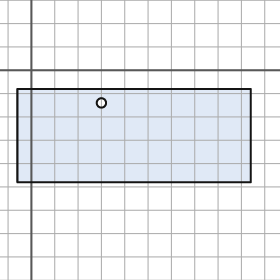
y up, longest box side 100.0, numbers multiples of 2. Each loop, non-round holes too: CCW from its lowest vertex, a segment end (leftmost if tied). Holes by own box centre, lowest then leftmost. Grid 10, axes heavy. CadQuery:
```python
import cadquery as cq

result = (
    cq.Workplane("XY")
    .moveTo(-6.0, -48.0)
    .lineTo(94.0, -48.0)
    .lineTo(94.0, -8.0)
    .lineTo(-6.0, -8.0)
    .close()
    .moveTo(30.0, -14.0)
    .circle(2.0)
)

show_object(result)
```